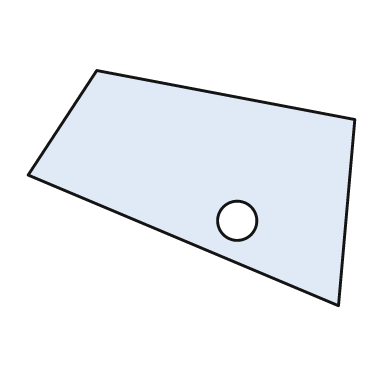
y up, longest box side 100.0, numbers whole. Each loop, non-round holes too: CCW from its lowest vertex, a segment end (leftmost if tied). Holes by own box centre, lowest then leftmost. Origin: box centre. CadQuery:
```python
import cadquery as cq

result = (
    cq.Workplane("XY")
    .moveTo(45.0, -36.0)
    .lineTo(50.0, 21.0)
    .lineTo(-29.0, 36.0)
    .lineTo(-50.0, 4.0)
    .close()
    .moveTo(14.0, -10.0)
    .circle(6.0)
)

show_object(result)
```